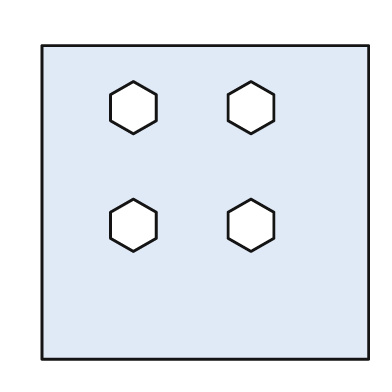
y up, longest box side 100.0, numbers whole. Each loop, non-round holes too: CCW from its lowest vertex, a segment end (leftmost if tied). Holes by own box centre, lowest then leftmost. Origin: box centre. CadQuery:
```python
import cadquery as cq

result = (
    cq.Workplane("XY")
    .moveTo(-50.0, -48.0)
    .lineTo(50.0, -48.0)
    .lineTo(50.0, 48.0)
    .lineTo(-50.0, 48.0)
    .close()
    .moveTo(-22.0, -15.0)
    .lineTo(-15.0, -11.0)
    .lineTo(-15.0, -3.0)
    .lineTo(-22.0, 1.0)
    .lineTo(-29.0, -3.0)
    .lineTo(-29.0, -11.0)
    .close()
    .moveTo(14.0, -15.0)
    .lineTo(21.0, -11.0)
    .lineTo(21.0, -3.0)
    .lineTo(14.0, 1.0)
    .lineTo(7.0, -3.0)
    .lineTo(7.0, -11.0)
    .close()
    .moveTo(-22.0, 21.0)
    .lineTo(-15.0, 25.0)
    .lineTo(-15.0, 33.0)
    .lineTo(-22.0, 37.0)
    .lineTo(-29.0, 33.0)
    .lineTo(-29.0, 25.0)
    .close()
    .moveTo(14.0, 21.0)
    .lineTo(21.0, 25.0)
    .lineTo(21.0, 33.0)
    .lineTo(14.0, 37.0)
    .lineTo(7.0, 33.0)
    .lineTo(7.0, 25.0)
    .close()
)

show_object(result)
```